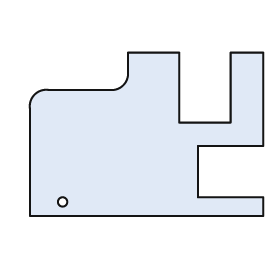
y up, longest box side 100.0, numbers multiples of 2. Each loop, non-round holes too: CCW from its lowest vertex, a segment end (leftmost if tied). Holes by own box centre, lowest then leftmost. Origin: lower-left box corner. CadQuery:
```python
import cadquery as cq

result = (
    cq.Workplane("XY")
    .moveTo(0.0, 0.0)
    .lineTo(100.0, 0.0)
    .lineTo(100.0, 8.0)
    .lineTo(72.0, 8.0)
    .lineTo(72.0, 30.0)
    .lineTo(100.0, 30.0)
    .lineTo(100.0, 70.0)
    .lineTo(86.0, 70.0)
    .lineTo(86.0, 40.0)
    .lineTo(64.0, 40.0)
    .lineTo(64.0, 70.0)
    .lineTo(42.0, 70.0)
    .lineTo(42.0, 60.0)
    .threePointArc((40.0, 56.0), (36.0, 54.0))
    .lineTo(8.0, 54.0)
    .threePointArc((2.0, 52.0), (0.0, 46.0))
    .close()
    .moveTo(14.0, 6.0)
    .circle(2.0)
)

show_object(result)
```